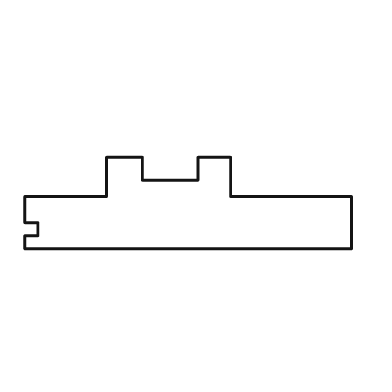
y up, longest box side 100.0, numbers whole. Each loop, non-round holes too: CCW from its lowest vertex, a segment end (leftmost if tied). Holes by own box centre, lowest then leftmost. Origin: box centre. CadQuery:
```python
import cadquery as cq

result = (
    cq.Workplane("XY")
    .moveTo(-50.0, -14.0)
    .lineTo(50.0, -14.0)
    .lineTo(50.0, 2.0)
    .lineTo(13.0, 2.0)
    .lineTo(13.0, 14.0)
    .lineTo(3.0, 14.0)
    .lineTo(3.0, 7.0)
    .lineTo(-14.0, 7.0)
    .lineTo(-14.0, 14.0)
    .lineTo(-25.0, 14.0)
    .lineTo(-25.0, 2.0)
    .lineTo(-50.0, 2.0)
    .lineTo(-50.0, -6.0)
    .lineTo(-46.0, -6.0)
    .lineTo(-46.0, -10.0)
    .lineTo(-50.0, -10.0)
    .close()
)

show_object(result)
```